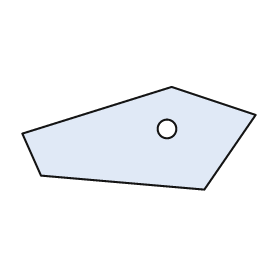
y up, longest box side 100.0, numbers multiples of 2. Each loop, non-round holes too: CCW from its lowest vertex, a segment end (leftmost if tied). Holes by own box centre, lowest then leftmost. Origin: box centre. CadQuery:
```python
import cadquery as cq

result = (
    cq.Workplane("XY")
    .moveTo(28.0, -22.0)
    .lineTo(50.0, 10.0)
    .lineTo(14.0, 22.0)
    .lineTo(-50.0, 2.0)
    .lineTo(-42.0, -16.0)
    .close()
    .moveTo(12.0, 4.0)
    .circle(4.0)
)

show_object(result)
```